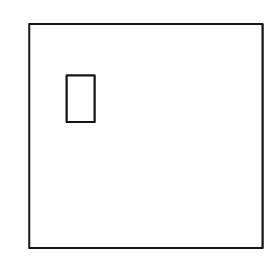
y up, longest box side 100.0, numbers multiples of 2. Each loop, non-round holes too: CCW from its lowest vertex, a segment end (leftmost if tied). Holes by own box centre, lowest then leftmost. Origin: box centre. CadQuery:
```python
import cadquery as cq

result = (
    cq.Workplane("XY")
    .moveTo(-50.0, -48.0)
    .lineTo(50.0, -48.0)
    .lineTo(50.0, 48.0)
    .lineTo(-50.0, 48.0)
    .close()
    .moveTo(-34.0, 6.0)
    .lineTo(-22.0, 6.0)
    .lineTo(-22.0, 26.0)
    .lineTo(-34.0, 26.0)
    .close()
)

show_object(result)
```